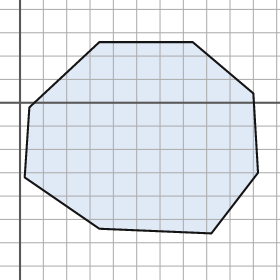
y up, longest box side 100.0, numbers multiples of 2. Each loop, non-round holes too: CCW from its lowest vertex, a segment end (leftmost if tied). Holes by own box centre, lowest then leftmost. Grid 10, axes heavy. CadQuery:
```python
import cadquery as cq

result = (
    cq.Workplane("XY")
    .moveTo(82.0, -56.0)
    .lineTo(102.0, -30.0)
    .lineTo(100.0, 4.0)
    .lineTo(74.0, 26.0)
    .lineTo(34.0, 26.0)
    .lineTo(4.0, -2.0)
    .lineTo(2.0, -32.0)
    .lineTo(34.0, -54.0)
    .close()
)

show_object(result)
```